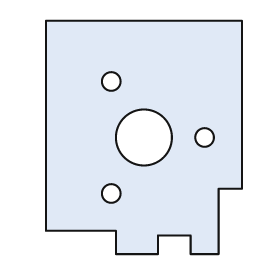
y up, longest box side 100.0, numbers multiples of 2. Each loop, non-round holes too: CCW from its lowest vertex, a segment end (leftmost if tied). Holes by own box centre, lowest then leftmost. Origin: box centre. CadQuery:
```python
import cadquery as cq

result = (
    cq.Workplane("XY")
    .moveTo(-12.0, -50.0)
    .lineTo(6.0, -50.0)
    .lineTo(6.0, -42.0)
    .lineTo(20.0, -42.0)
    .lineTo(20.0, -50.0)
    .lineTo(32.0, -50.0)
    .lineTo(32.0, -22.0)
    .lineTo(42.0, -22.0)
    .lineTo(42.0, 50.0)
    .lineTo(-42.0, 50.0)
    .lineTo(-42.0, -40.0)
    .lineTo(-12.0, -40.0)
    .close()
    .moveTo(-14.0, -24.0)
    .circle(4.0)
    .moveTo(0.0, 0.0)
    .circle(12.0)
    .moveTo(26.0, 0.0)
    .circle(4.0)
    .moveTo(-14.0, 24.0)
    .circle(4.0)
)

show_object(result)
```